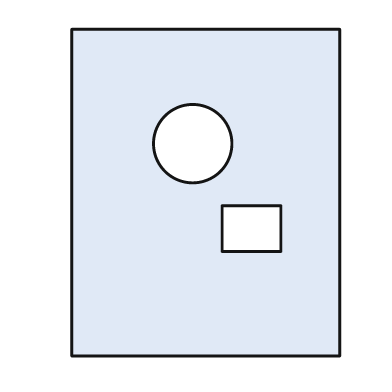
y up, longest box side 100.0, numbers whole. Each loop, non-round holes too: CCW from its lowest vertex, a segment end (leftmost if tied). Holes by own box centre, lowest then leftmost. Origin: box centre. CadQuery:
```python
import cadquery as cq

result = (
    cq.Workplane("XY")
    .moveTo(-41.0, -50.0)
    .lineTo(41.0, -50.0)
    .lineTo(41.0, 50.0)
    .lineTo(-41.0, 50.0)
    .close()
    .moveTo(5.0, -18.0)
    .lineTo(23.0, -18.0)
    .lineTo(23.0, -4.0)
    .lineTo(5.0, -4.0)
    .close()
    .moveTo(-4.0, 15.0)
    .circle(12.0)
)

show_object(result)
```